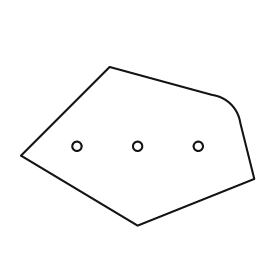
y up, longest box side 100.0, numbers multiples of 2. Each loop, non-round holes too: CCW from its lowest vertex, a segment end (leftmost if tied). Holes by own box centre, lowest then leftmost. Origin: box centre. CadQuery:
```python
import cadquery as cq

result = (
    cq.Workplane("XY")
    .moveTo(0.0, -34.0)
    .lineTo(50.0, -14.0)
    .lineTo(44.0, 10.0)
    .threePointArc((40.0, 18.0), (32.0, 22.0))
    .lineTo(-12.0, 34.0)
    .lineTo(-50.0, -4.0)
    .close()
    .moveTo(-26.0, 0.0)
    .circle(2.0)
    .moveTo(0.0, 0.0)
    .circle(2.0)
    .moveTo(26.0, 0.0)
    .circle(2.0)
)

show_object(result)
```